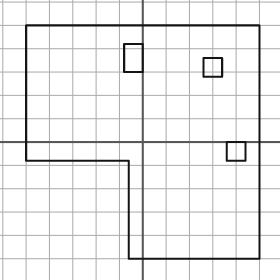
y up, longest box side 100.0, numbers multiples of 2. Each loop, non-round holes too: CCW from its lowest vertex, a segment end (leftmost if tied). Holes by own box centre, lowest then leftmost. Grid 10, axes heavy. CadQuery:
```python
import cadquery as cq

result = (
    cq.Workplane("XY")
    .moveTo(-6.0, -50.0)
    .lineTo(50.0, -50.0)
    .lineTo(50.0, 50.0)
    .lineTo(-50.0, 50.0)
    .lineTo(-50.0, -8.0)
    .lineTo(-6.0, -8.0)
    .close()
    .moveTo(36.0, -8.0)
    .lineTo(44.0, -8.0)
    .lineTo(44.0, 0.0)
    .lineTo(36.0, 0.0)
    .close()
    .moveTo(26.0, 28.0)
    .lineTo(34.0, 28.0)
    .lineTo(34.0, 36.0)
    .lineTo(26.0, 36.0)
    .close()
    .moveTo(-8.0, 30.0)
    .lineTo(0.0, 30.0)
    .lineTo(0.0, 42.0)
    .lineTo(-8.0, 42.0)
    .close()
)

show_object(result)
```